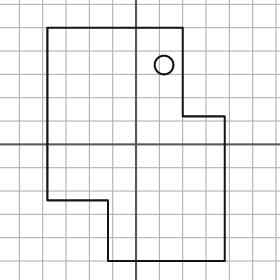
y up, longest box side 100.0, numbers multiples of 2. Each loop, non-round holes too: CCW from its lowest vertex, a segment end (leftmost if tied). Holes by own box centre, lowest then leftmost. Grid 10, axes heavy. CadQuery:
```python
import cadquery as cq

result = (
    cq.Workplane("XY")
    .moveTo(-12.0, -50.0)
    .lineTo(38.0, -50.0)
    .lineTo(38.0, 12.0)
    .lineTo(20.0, 12.0)
    .lineTo(20.0, 50.0)
    .lineTo(-38.0, 50.0)
    .lineTo(-38.0, -24.0)
    .lineTo(-12.0, -24.0)
    .close()
    .moveTo(12.0, 34.0)
    .circle(4.0)
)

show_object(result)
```